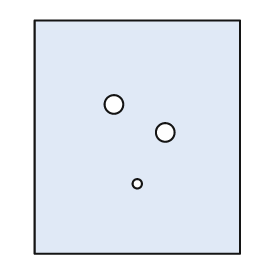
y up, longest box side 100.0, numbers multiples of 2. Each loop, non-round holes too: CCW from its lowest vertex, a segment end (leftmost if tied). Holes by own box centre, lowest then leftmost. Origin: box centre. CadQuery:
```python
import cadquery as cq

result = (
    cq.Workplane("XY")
    .moveTo(-44.0, -50.0)
    .lineTo(44.0, -50.0)
    .lineTo(44.0, 50.0)
    .lineTo(-44.0, 50.0)
    .close()
    .moveTo(0.0, -20.0)
    .circle(2.0)
    .moveTo(12.0, 2.0)
    .circle(4.0)
    .moveTo(-10.0, 14.0)
    .circle(4.0)
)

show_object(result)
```